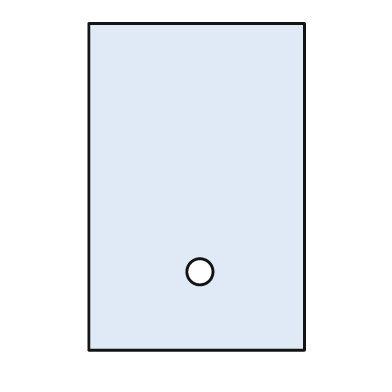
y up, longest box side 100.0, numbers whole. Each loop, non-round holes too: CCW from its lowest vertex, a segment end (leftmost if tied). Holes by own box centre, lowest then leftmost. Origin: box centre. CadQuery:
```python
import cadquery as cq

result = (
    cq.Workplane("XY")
    .moveTo(-33.0, -50.0)
    .lineTo(33.0, -50.0)
    .lineTo(33.0, 50.0)
    .lineTo(-33.0, 50.0)
    .close()
    .moveTo(1.0, -26.0)
    .circle(4.0)
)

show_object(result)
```